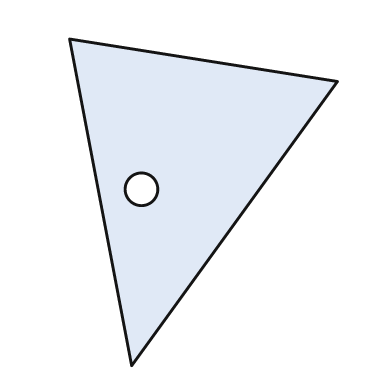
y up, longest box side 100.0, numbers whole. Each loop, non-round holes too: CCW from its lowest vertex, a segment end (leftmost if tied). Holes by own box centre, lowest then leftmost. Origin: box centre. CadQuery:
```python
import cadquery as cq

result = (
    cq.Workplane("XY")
    .moveTo(-22.0, -50.0)
    .lineTo(41.0, 37.0)
    .lineTo(-41.0, 50.0)
    .close()
    .moveTo(-19.0, 4.0)
    .circle(5.0)
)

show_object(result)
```